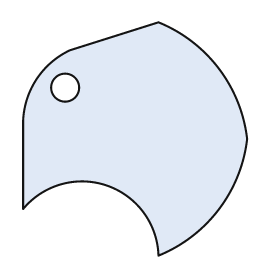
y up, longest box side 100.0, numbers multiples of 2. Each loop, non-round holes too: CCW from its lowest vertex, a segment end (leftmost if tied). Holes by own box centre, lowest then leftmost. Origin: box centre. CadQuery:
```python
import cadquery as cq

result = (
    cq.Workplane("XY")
    .moveTo(10.0, -50.0)
    .threePointArc((36.0, -30.0), (48.0, 0.0))
    .threePointArc((36.0, 30.0), (10.0, 50.0))
    .lineTo(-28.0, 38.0)
    .threePointArc((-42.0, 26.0), (-48.0, 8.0))
    .lineTo(-48.0, -30.0)
    .threePointArc((-12.0, -20.0), (10.0, -50.0))
    .close()
    .moveTo(-30.0, 22.0)
    .circle(6.0)
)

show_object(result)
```